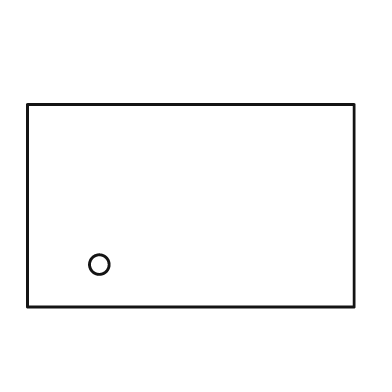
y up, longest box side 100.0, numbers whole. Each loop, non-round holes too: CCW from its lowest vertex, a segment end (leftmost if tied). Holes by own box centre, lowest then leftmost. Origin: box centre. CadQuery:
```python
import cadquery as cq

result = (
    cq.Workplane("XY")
    .moveTo(-50.0, -31.0)
    .lineTo(50.0, -31.0)
    .lineTo(50.0, 31.0)
    .lineTo(-50.0, 31.0)
    .close()
    .moveTo(-28.0, -18.0)
    .circle(3.0)
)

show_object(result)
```